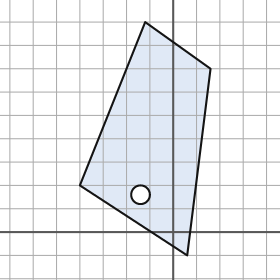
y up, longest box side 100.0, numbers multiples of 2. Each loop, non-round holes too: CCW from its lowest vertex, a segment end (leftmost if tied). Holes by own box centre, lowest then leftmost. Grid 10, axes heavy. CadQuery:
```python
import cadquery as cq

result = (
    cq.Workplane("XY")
    .moveTo(6.0, -10.0)
    .lineTo(16.0, 70.0)
    .lineTo(-12.0, 90.0)
    .lineTo(-40.0, 20.0)
    .close()
    .moveTo(-14.0, 16.0)
    .circle(4.0)
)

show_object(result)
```